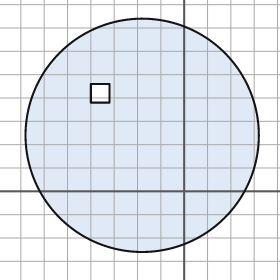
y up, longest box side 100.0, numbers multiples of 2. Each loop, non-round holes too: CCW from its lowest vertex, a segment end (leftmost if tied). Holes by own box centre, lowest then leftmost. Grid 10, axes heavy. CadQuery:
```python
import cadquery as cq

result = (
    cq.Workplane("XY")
    .moveTo(-18.0, 24.0)
    .circle(50.0)
    .moveTo(-40.0, 38.0)
    .lineTo(-32.0, 38.0)
    .lineTo(-32.0, 46.0)
    .lineTo(-40.0, 46.0)
    .close()
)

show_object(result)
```